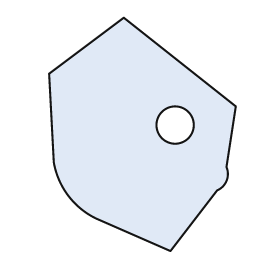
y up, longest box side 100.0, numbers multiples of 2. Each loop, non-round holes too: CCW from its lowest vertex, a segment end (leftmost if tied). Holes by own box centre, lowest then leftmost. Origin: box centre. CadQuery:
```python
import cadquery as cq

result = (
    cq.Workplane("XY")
    .moveTo(12.0, -50.0)
    .lineTo(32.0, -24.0)
    .threePointArc((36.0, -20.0), (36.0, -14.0))
    .lineTo(40.0, 12.0)
    .lineTo(-8.0, 50.0)
    .lineTo(-40.0, 26.0)
    .lineTo(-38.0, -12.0)
    .threePointArc((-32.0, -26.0), (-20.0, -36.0))
    .close()
    .moveTo(14.0, 4.0)
    .circle(8.0)
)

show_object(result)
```